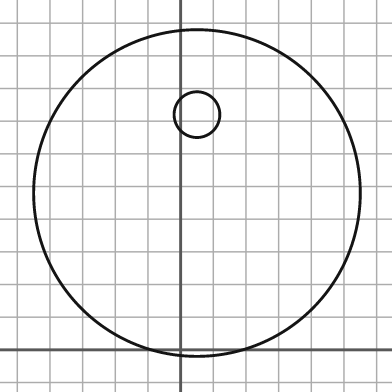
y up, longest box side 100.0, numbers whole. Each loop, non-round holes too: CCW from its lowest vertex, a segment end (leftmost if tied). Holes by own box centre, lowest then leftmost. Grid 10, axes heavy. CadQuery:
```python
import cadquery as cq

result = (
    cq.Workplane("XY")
    .moveTo(5.0, 48.0)
    .circle(50.0)
    .moveTo(5.0, 72.0)
    .circle(7.0)
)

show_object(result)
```